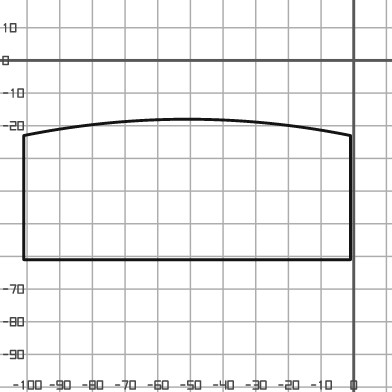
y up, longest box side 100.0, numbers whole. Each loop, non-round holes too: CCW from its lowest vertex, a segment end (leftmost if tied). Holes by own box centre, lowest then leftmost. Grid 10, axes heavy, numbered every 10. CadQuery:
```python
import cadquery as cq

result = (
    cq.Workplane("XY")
    .moveTo(-101.0, -61.0)
    .lineTo(-1.0, -61.0)
    .lineTo(-1.0, -23.0)
    .threePointArc((-51.0, -18.0), (-101.0, -23.0))
    .close()
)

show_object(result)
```